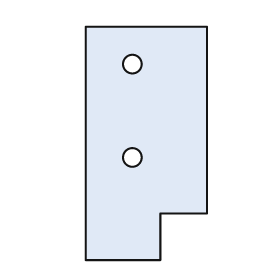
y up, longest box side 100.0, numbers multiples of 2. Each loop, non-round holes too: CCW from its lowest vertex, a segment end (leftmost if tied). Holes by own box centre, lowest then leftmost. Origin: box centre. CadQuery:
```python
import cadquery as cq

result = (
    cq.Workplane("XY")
    .moveTo(-26.0, -50.0)
    .lineTo(6.0, -50.0)
    .lineTo(6.0, -30.0)
    .lineTo(26.0, -30.0)
    .lineTo(26.0, 50.0)
    .lineTo(-26.0, 50.0)
    .close()
    .moveTo(-6.0, -6.0)
    .circle(4.0)
    .moveTo(-6.0, 34.0)
    .circle(4.0)
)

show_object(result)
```